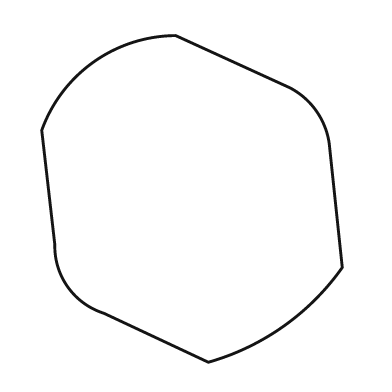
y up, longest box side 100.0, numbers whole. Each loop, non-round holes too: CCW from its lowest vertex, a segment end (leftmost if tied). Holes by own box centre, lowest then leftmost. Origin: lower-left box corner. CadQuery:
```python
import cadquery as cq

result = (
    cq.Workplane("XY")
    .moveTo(51.0, 0.0)
    .threePointArc((74.0, 11.0), (92.0, 29.0))
    .lineTo(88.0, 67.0)
    .threePointArc((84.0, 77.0), (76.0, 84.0))
    .lineTo(41.0, 100.0)
    .threePointArc((16.0, 92.0), (0.0, 71.0))
    .lineTo(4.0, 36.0)
    .threePointArc((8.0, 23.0), (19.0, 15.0))
    .close()
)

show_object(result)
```